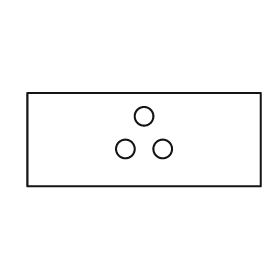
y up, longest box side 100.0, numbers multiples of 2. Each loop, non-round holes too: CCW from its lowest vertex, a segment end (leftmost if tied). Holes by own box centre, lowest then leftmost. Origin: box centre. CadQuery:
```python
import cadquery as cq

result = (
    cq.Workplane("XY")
    .moveTo(-50.0, -20.0)
    .lineTo(50.0, -20.0)
    .lineTo(50.0, 20.0)
    .lineTo(-50.0, 20.0)
    .close()
    .moveTo(-8.0, -4.0)
    .circle(4.0)
    .moveTo(8.0, -4.0)
    .circle(4.0)
    .moveTo(0.0, 10.0)
    .circle(4.0)
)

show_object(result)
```